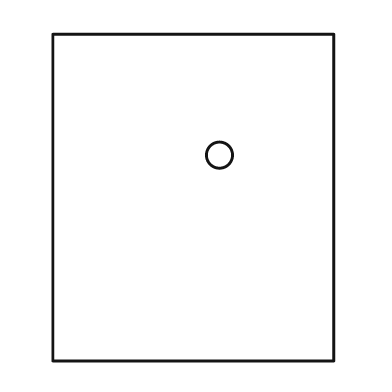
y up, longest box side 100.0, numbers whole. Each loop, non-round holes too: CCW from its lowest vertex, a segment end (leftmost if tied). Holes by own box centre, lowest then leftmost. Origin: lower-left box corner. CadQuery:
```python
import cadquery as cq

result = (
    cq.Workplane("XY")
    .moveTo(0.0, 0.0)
    .lineTo(86.0, 0.0)
    .lineTo(86.0, 100.0)
    .lineTo(0.0, 100.0)
    .close()
    .moveTo(51.0, 63.0)
    .circle(4.0)
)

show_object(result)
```